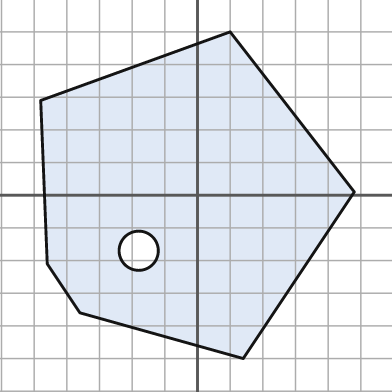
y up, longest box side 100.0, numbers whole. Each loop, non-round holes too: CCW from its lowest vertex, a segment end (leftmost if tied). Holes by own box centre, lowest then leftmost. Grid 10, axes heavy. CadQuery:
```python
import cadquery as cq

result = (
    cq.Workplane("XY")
    .moveTo(14.0, -50.0)
    .lineTo(48.0, 1.0)
    .lineTo(10.0, 50.0)
    .lineTo(-48.0, 29.0)
    .lineTo(-46.0, -21.0)
    .lineTo(-36.0, -36.0)
    .close()
    .moveTo(-18.0, -17.0)
    .circle(6.0)
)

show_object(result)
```